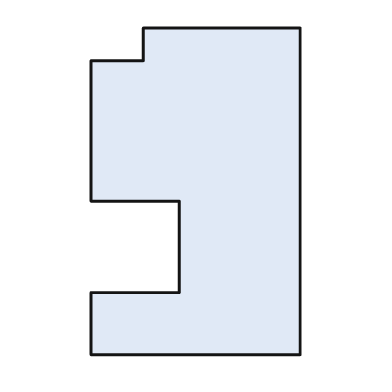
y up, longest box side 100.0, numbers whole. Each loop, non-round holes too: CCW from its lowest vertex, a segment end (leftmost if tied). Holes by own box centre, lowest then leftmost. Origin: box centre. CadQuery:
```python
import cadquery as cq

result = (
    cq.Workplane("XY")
    .moveTo(-32.0, -50.0)
    .lineTo(32.0, -50.0)
    .lineTo(32.0, 50.0)
    .lineTo(-16.0, 50.0)
    .lineTo(-16.0, 40.0)
    .lineTo(-32.0, 40.0)
    .lineTo(-32.0, -3.0)
    .lineTo(-5.0, -3.0)
    .lineTo(-5.0, -31.0)
    .lineTo(-32.0, -31.0)
    .close()
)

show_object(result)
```